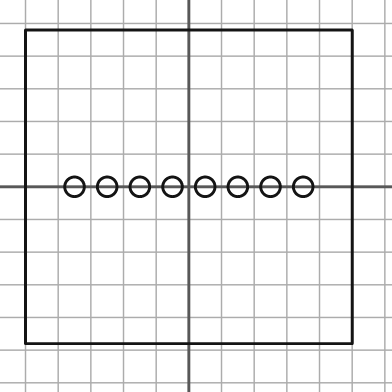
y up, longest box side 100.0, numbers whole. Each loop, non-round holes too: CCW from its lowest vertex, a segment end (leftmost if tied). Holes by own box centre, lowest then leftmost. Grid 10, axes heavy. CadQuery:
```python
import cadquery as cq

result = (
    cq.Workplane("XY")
    .moveTo(-50.0, -48.0)
    .lineTo(50.0, -48.0)
    .lineTo(50.0, 48.0)
    .lineTo(-50.0, 48.0)
    .close()
    .moveTo(-35.0, 0.0)
    .circle(3.0)
    .moveTo(-25.0, 0.0)
    .circle(3.0)
    .moveTo(-15.0, 0.0)
    .circle(3.0)
    .moveTo(-5.0, 0.0)
    .circle(3.0)
    .moveTo(5.0, 0.0)
    .circle(3.0)
    .moveTo(15.0, 0.0)
    .circle(3.0)
    .moveTo(25.0, 0.0)
    .circle(3.0)
    .moveTo(35.0, 0.0)
    .circle(3.0)
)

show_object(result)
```